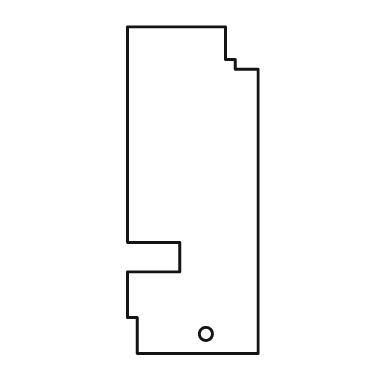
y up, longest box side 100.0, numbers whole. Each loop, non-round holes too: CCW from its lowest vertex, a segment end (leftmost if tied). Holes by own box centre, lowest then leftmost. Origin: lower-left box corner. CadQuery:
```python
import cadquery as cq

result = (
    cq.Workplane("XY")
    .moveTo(3.0, 0.0)
    .lineTo(40.0, 0.0)
    .lineTo(40.0, 87.0)
    .lineTo(33.0, 87.0)
    .lineTo(33.0, 90.0)
    .lineTo(30.0, 90.0)
    .lineTo(30.0, 100.0)
    .lineTo(0.0, 100.0)
    .lineTo(0.0, 34.0)
    .lineTo(16.0, 34.0)
    .lineTo(16.0, 25.0)
    .lineTo(0.0, 25.0)
    .lineTo(0.0, 11.0)
    .lineTo(3.0, 11.0)
    .close()
    .moveTo(24.0, 6.0)
    .circle(2.0)
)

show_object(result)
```